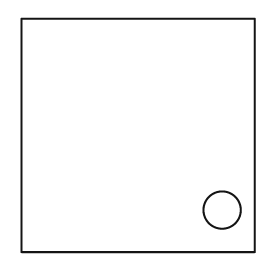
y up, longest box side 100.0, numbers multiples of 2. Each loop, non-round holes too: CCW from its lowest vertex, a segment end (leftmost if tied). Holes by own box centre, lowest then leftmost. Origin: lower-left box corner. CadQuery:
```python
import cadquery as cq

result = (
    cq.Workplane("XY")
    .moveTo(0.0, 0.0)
    .lineTo(100.0, 0.0)
    .lineTo(100.0, 100.0)
    .lineTo(0.0, 100.0)
    .close()
    .moveTo(86.0, 18.0)
    .circle(8.0)
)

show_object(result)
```